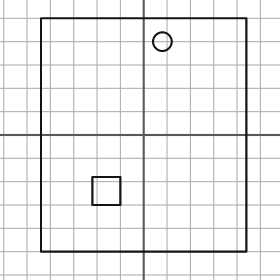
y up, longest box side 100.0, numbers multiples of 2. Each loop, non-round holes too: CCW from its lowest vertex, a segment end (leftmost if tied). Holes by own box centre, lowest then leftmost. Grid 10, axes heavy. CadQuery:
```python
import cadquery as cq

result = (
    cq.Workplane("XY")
    .moveTo(-44.0, -50.0)
    .lineTo(44.0, -50.0)
    .lineTo(44.0, 50.0)
    .lineTo(-44.0, 50.0)
    .close()
    .moveTo(-22.0, -30.0)
    .lineTo(-10.0, -30.0)
    .lineTo(-10.0, -18.0)
    .lineTo(-22.0, -18.0)
    .close()
    .moveTo(8.0, 40.0)
    .circle(4.0)
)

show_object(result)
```